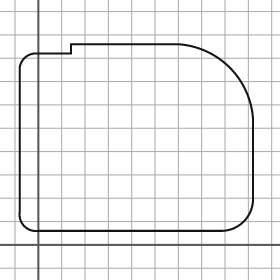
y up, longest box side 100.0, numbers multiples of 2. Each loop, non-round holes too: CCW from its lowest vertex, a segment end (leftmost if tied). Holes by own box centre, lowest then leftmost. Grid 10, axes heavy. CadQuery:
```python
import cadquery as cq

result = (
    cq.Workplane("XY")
    .moveTo(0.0, 6.0)
    .lineTo(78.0, 6.0)
    .threePointArc((88.0, 10.0), (92.0, 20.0))
    .lineTo(92.0, 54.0)
    .threePointArc((82.0, 76.0), (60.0, 86.0))
    .lineTo(14.0, 86.0)
    .lineTo(14.0, 82.0)
    .lineTo(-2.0, 82.0)
    .threePointArc((-6.0, 80.0), (-8.0, 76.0))
    .lineTo(-8.0, 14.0)
    .threePointArc((-6.0, 8.0), (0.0, 6.0))
    .close()
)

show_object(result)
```